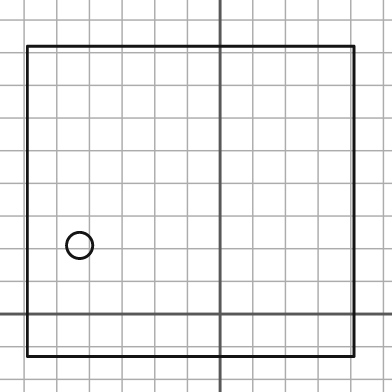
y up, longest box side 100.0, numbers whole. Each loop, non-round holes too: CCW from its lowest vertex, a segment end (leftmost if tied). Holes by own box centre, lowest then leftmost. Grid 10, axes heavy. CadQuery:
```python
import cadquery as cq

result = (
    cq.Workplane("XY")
    .moveTo(-59.0, -13.0)
    .lineTo(41.0, -13.0)
    .lineTo(41.0, 82.0)
    .lineTo(-59.0, 82.0)
    .close()
    .moveTo(-43.0, 21.0)
    .circle(4.0)
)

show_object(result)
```